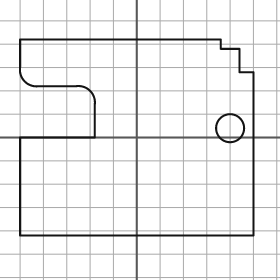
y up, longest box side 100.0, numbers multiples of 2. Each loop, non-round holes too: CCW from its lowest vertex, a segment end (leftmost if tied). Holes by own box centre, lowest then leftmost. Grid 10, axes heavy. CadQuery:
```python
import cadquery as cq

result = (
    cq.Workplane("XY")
    .moveTo(-50.0, -42.0)
    .lineTo(50.0, -42.0)
    .lineTo(50.0, 28.0)
    .lineTo(44.0, 28.0)
    .lineTo(44.0, 38.0)
    .lineTo(36.0, 38.0)
    .lineTo(36.0, 42.0)
    .lineTo(-50.0, 42.0)
    .lineTo(-50.0, 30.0)
    .threePointArc((-48.0, 24.0), (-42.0, 22.0))
    .lineTo(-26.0, 22.0)
    .threePointArc((-20.0, 20.0), (-18.0, 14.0))
    .lineTo(-18.0, 0.0)
    .lineTo(-50.0, 0.0)
    .close()
    .moveTo(40.0, 4.0)
    .circle(6.0)
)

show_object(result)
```